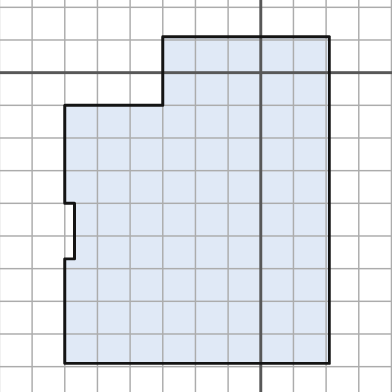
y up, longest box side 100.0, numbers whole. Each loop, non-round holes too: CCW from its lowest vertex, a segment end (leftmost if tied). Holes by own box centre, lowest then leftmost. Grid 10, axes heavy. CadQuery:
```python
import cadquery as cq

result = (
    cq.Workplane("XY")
    .moveTo(-60.0, -89.0)
    .lineTo(21.0, -89.0)
    .lineTo(21.0, 11.0)
    .lineTo(-30.0, 11.0)
    .lineTo(-30.0, -10.0)
    .lineTo(-60.0, -10.0)
    .lineTo(-60.0, -40.0)
    .lineTo(-57.0, -40.0)
    .lineTo(-57.0, -57.0)
    .lineTo(-60.0, -57.0)
    .close()
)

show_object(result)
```